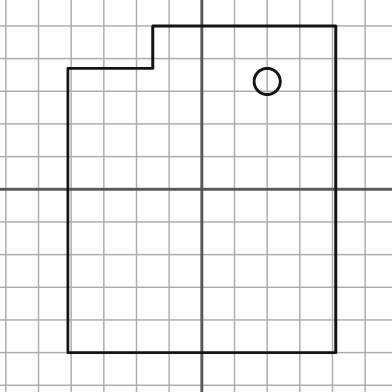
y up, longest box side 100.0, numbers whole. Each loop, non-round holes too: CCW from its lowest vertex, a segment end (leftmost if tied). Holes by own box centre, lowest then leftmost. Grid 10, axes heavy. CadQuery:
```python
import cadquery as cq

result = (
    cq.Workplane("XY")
    .moveTo(-41.0, -50.0)
    .lineTo(41.0, -50.0)
    .lineTo(41.0, 50.0)
    .lineTo(-15.0, 50.0)
    .lineTo(-15.0, 37.0)
    .lineTo(-41.0, 37.0)
    .close()
    .moveTo(20.0, 33.0)
    .circle(4.0)
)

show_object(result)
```